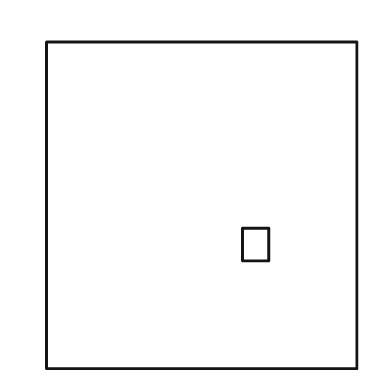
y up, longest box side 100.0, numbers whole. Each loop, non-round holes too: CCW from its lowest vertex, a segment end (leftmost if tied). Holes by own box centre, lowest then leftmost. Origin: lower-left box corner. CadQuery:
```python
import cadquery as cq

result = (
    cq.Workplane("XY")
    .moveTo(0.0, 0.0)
    .lineTo(95.0, 0.0)
    .lineTo(95.0, 100.0)
    .lineTo(0.0, 100.0)
    .close()
    .moveTo(60.0, 33.0)
    .lineTo(68.0, 33.0)
    .lineTo(68.0, 43.0)
    .lineTo(60.0, 43.0)
    .close()
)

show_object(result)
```